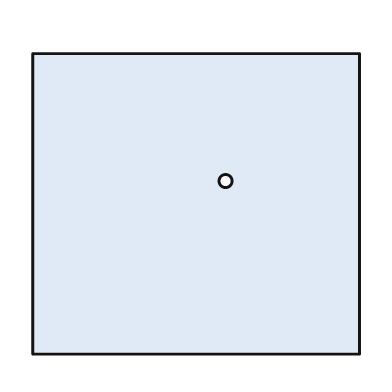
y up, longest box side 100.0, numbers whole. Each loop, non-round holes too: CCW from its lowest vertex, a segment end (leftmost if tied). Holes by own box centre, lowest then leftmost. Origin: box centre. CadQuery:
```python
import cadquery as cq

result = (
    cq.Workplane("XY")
    .moveTo(-50.0, -46.0)
    .lineTo(50.0, -46.0)
    .lineTo(50.0, 46.0)
    .lineTo(-50.0, 46.0)
    .close()
    .moveTo(9.0, 7.0)
    .circle(2.0)
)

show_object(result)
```